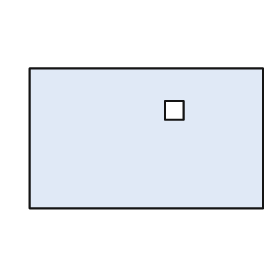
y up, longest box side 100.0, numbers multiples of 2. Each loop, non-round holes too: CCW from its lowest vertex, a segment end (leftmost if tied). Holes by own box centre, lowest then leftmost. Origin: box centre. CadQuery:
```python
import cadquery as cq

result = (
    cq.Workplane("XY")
    .moveTo(-50.0, -30.0)
    .lineTo(50.0, -30.0)
    .lineTo(50.0, 30.0)
    .lineTo(-50.0, 30.0)
    .close()
    .moveTo(8.0, 8.0)
    .lineTo(16.0, 8.0)
    .lineTo(16.0, 16.0)
    .lineTo(8.0, 16.0)
    .close()
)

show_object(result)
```